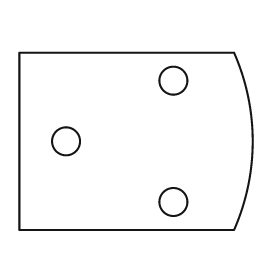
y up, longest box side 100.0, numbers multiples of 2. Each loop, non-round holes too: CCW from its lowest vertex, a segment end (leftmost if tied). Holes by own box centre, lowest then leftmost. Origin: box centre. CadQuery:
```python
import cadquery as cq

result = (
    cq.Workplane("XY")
    .moveTo(-50.0, -38.0)
    .lineTo(42.0, -38.0)
    .threePointArc((50.0, 0.0), (42.0, 38.0))
    .lineTo(-50.0, 38.0)
    .close()
    .moveTo(16.0, -26.0)
    .circle(6.0)
    .moveTo(-30.0, 0.0)
    .circle(6.0)
    .moveTo(16.0, 26.0)
    .circle(6.0)
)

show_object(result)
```